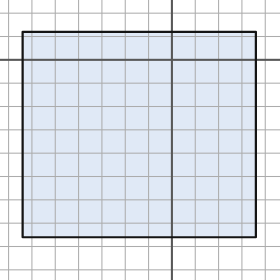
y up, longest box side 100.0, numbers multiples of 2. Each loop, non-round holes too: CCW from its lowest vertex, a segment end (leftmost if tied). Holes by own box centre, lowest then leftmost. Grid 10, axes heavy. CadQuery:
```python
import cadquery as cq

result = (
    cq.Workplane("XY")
    .moveTo(-64.0, -76.0)
    .lineTo(36.0, -76.0)
    .lineTo(36.0, 12.0)
    .lineTo(-64.0, 12.0)
    .close()
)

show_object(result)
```